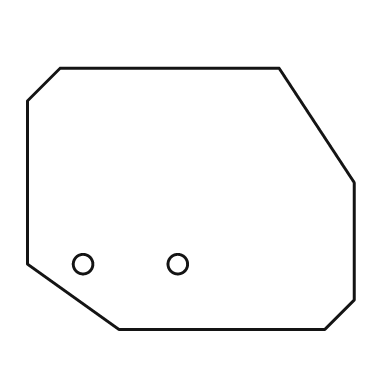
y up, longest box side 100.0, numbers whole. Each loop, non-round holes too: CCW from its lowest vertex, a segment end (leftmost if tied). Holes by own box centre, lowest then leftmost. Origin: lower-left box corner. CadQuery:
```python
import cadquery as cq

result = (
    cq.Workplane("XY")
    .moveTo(28.0, 0.0)
    .lineTo(91.0, 0.0)
    .lineTo(100.0, 9.0)
    .lineTo(100.0, 45.0)
    .lineTo(77.0, 80.0)
    .lineTo(10.0, 80.0)
    .lineTo(0.0, 70.0)
    .lineTo(0.0, 20.0)
    .close()
    .moveTo(17.0, 20.0)
    .circle(3.0)
    .moveTo(46.0, 20.0)
    .circle(3.0)
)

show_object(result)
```